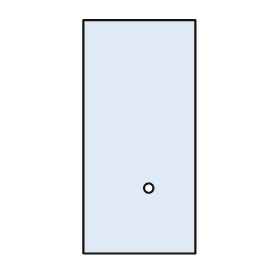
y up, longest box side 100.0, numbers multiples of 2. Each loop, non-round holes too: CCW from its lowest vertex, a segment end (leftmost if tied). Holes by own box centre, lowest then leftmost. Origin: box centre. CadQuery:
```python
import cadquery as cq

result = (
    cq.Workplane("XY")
    .moveTo(-24.0, -50.0)
    .lineTo(24.0, -50.0)
    .lineTo(24.0, 50.0)
    .lineTo(-24.0, 50.0)
    .close()
    .moveTo(4.0, -22.0)
    .circle(2.0)
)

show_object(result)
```